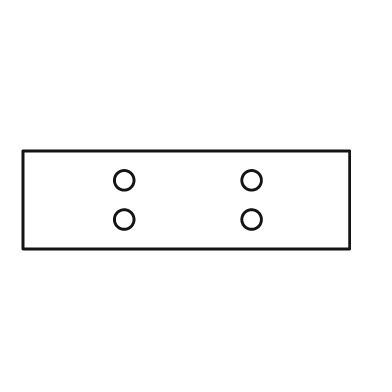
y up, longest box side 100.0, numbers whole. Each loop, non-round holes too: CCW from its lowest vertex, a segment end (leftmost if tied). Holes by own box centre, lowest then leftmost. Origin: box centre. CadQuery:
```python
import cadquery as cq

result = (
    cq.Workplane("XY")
    .moveTo(-50.0, -15.0)
    .lineTo(50.0, -15.0)
    .lineTo(50.0, 15.0)
    .lineTo(-50.0, 15.0)
    .close()
    .moveTo(-19.0, -6.0)
    .circle(3.0)
    .moveTo(20.0, -6.0)
    .circle(3.0)
    .moveTo(-19.0, 6.0)
    .circle(3.0)
    .moveTo(20.0, 6.0)
    .circle(3.0)
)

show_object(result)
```